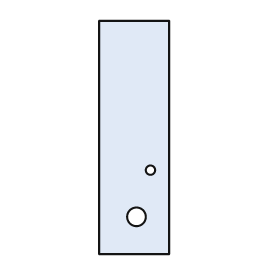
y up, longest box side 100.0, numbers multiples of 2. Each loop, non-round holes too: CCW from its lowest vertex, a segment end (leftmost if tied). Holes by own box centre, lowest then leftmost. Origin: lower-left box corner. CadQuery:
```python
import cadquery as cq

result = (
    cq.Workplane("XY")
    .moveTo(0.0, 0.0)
    .lineTo(30.0, 0.0)
    .lineTo(30.0, 100.0)
    .lineTo(0.0, 100.0)
    .close()
    .moveTo(16.0, 16.0)
    .circle(4.0)
    .moveTo(22.0, 36.0)
    .circle(2.0)
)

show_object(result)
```